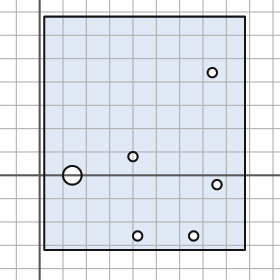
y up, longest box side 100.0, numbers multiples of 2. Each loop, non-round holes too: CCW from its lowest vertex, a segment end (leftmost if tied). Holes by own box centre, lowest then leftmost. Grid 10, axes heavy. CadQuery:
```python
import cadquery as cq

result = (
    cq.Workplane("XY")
    .moveTo(2.0, -32.0)
    .lineTo(88.0, -32.0)
    .lineTo(88.0, 68.0)
    .lineTo(2.0, 68.0)
    .close()
    .moveTo(42.0, -26.0)
    .circle(2.0)
    .moveTo(66.0, -26.0)
    .circle(2.0)
    .moveTo(76.0, -4.0)
    .circle(2.0)
    .moveTo(14.0, 0.0)
    .circle(4.0)
    .moveTo(40.0, 8.0)
    .circle(2.0)
    .moveTo(74.0, 44.0)
    .circle(2.0)
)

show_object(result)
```